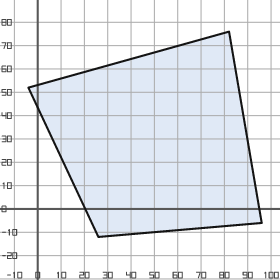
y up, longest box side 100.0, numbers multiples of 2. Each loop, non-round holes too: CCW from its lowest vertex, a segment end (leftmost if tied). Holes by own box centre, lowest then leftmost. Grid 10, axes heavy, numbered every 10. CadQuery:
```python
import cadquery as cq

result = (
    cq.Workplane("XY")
    .moveTo(26.0, -12.0)
    .lineTo(96.0, -6.0)
    .lineTo(82.0, 76.0)
    .lineTo(-4.0, 52.0)
    .close()
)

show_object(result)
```